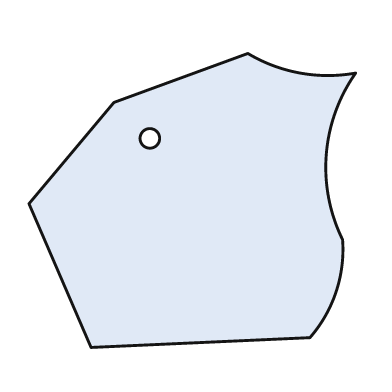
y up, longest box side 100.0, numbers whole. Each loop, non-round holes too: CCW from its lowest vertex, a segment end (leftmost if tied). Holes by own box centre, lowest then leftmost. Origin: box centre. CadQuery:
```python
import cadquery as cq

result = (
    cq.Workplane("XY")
    .moveTo(-31.0, -45.0)
    .lineTo(36.0, -42.0)
    .threePointArc((44.0, -28.0), (46.0, -12.0))
    .threePointArc((41.0, 14.0), (50.0, 39.0))
    .threePointArc((33.0, 39.0), (17.0, 45.0))
    .lineTo(-24.0, 30.0)
    .lineTo(-50.0, -1.0)
    .close()
    .moveTo(-13.0, 19.0)
    .circle(3.0)
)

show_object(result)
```